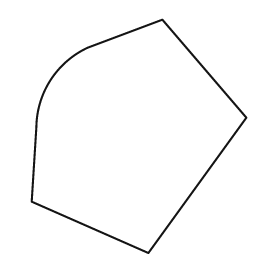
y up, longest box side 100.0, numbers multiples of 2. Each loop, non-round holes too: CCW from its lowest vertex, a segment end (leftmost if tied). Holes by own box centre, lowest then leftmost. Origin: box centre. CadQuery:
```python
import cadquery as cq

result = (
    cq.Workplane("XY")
    .moveTo(4.0, -50.0)
    .lineTo(46.0, 8.0)
    .lineTo(10.0, 50.0)
    .lineTo(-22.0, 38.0)
    .threePointArc((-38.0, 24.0), (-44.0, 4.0))
    .lineTo(-46.0, -28.0)
    .close()
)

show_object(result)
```